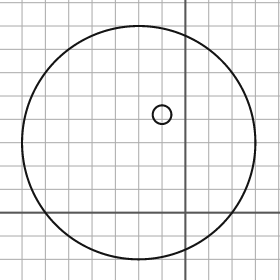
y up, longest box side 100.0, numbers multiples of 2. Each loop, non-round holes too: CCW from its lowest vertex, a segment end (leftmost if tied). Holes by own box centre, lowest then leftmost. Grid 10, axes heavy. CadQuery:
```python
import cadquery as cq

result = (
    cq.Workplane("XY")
    .moveTo(-20.0, 30.0)
    .circle(50.0)
    .moveTo(-10.0, 42.0)
    .circle(4.0)
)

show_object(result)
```